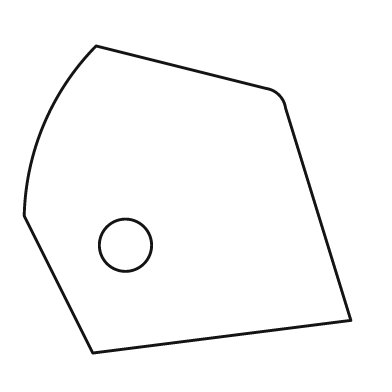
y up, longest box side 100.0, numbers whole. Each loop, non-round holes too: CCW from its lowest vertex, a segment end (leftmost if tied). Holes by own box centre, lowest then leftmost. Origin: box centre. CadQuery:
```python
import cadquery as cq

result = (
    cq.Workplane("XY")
    .moveTo(-29.0, -47.0)
    .lineTo(50.0, -37.0)
    .lineTo(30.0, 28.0)
    .threePointArc((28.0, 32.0), (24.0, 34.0))
    .lineTo(-28.0, 47.0)
    .threePointArc((-44.0, 23.0), (-50.0, -5.0))
    .close()
    .moveTo(-19.0, -14.0)
    .circle(8.0)
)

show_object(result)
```